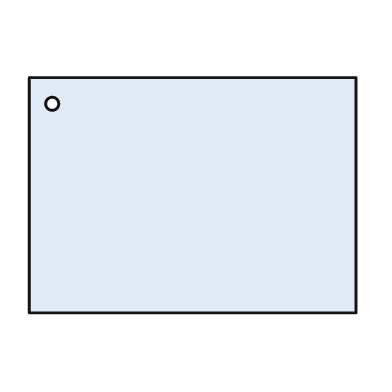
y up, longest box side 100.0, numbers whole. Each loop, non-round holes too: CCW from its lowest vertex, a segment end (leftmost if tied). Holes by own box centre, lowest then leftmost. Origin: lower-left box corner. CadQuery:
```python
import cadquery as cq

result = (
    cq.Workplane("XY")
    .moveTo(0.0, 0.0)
    .lineTo(100.0, 0.0)
    .lineTo(100.0, 72.0)
    .lineTo(0.0, 72.0)
    .close()
    .moveTo(7.0, 64.0)
    .circle(2.0)
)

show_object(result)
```